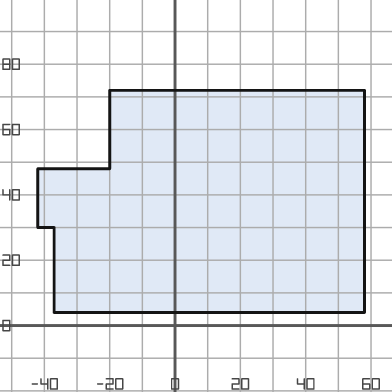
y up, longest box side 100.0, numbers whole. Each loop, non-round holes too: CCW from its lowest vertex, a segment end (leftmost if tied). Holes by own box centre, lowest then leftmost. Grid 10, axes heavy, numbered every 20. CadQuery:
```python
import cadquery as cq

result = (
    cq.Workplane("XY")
    .moveTo(-37.0, 4.0)
    .lineTo(58.0, 4.0)
    .lineTo(58.0, 72.0)
    .lineTo(-20.0, 72.0)
    .lineTo(-20.0, 48.0)
    .lineTo(-42.0, 48.0)
    .lineTo(-42.0, 30.0)
    .lineTo(-37.0, 30.0)
    .close()
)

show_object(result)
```